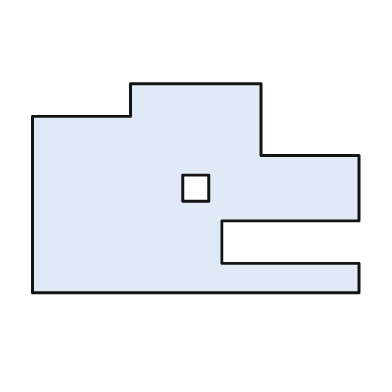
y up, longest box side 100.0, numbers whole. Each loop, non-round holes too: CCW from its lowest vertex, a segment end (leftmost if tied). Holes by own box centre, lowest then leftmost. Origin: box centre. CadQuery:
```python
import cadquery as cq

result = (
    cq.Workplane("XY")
    .moveTo(-50.0, -32.0)
    .lineTo(50.0, -32.0)
    .lineTo(50.0, -23.0)
    .lineTo(8.0, -23.0)
    .lineTo(8.0, -10.0)
    .lineTo(50.0, -10.0)
    .lineTo(50.0, 10.0)
    .lineTo(20.0, 10.0)
    .lineTo(20.0, 32.0)
    .lineTo(-20.0, 32.0)
    .lineTo(-20.0, 22.0)
    .lineTo(-50.0, 22.0)
    .close()
    .moveTo(-4.0, -4.0)
    .lineTo(4.0, -4.0)
    .lineTo(4.0, 4.0)
    .lineTo(-4.0, 4.0)
    .close()
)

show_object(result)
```